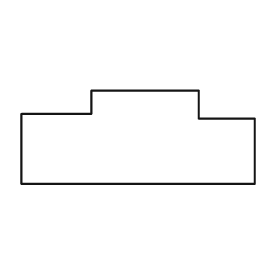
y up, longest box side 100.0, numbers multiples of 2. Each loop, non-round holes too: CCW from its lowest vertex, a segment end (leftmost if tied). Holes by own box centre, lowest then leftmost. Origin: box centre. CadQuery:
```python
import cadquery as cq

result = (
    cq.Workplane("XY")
    .moveTo(-50.0, -20.0)
    .lineTo(50.0, -20.0)
    .lineTo(50.0, 8.0)
    .lineTo(26.0, 8.0)
    .lineTo(26.0, 20.0)
    .lineTo(-20.0, 20.0)
    .lineTo(-20.0, 10.0)
    .lineTo(-50.0, 10.0)
    .close()
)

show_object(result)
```